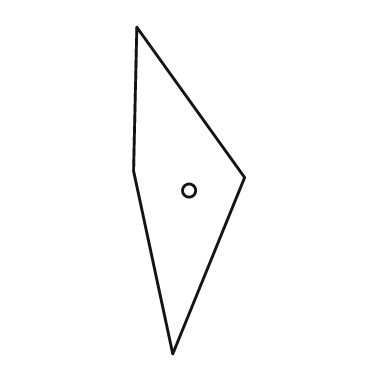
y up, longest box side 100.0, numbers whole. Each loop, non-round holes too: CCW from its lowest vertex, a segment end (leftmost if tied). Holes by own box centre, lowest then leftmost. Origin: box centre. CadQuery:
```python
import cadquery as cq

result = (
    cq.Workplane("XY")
    .moveTo(-5.0, -50.0)
    .lineTo(17.0, 4.0)
    .lineTo(-16.0, 50.0)
    .lineTo(-17.0, 6.0)
    .close()
    .moveTo(0.0, 0.0)
    .circle(2.0)
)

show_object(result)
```